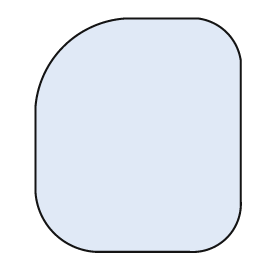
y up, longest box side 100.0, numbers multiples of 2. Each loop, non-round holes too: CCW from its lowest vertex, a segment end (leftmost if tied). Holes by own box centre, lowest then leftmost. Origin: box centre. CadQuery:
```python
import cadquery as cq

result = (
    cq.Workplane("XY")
    .moveTo(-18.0, -50.0)
    .lineTo(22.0, -50.0)
    .threePointArc((38.0, -44.0), (44.0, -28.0))
    .lineTo(44.0, 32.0)
    .threePointArc((38.0, 44.0), (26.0, 50.0))
    .lineTo(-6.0, 50.0)
    .threePointArc((-32.0, 38.0), (-44.0, 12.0))
    .lineTo(-44.0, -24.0)
    .threePointArc((-36.0, -42.0), (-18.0, -50.0))
    .close()
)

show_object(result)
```